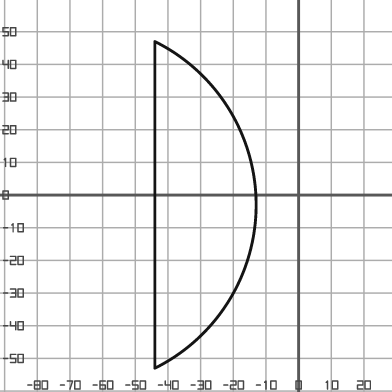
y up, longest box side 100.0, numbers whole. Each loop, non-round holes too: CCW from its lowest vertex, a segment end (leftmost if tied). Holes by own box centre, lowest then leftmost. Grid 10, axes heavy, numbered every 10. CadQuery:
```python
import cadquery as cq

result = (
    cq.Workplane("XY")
    .moveTo(-44.0, -53.0)
    .threePointArc((-13.0, -3.0), (-44.0, 47.0))
    .close()
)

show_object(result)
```